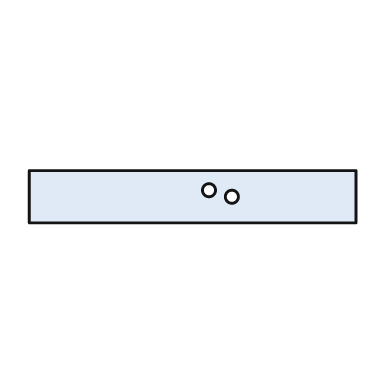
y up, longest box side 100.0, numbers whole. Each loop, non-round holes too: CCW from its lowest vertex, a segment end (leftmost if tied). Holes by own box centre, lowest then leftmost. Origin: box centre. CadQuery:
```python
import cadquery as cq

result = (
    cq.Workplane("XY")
    .moveTo(-50.0, -8.0)
    .lineTo(50.0, -8.0)
    .lineTo(50.0, 8.0)
    .lineTo(-50.0, 8.0)
    .close()
    .moveTo(12.0, 0.0)
    .circle(2.0)
    .moveTo(5.0, 2.0)
    .circle(2.0)
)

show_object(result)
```